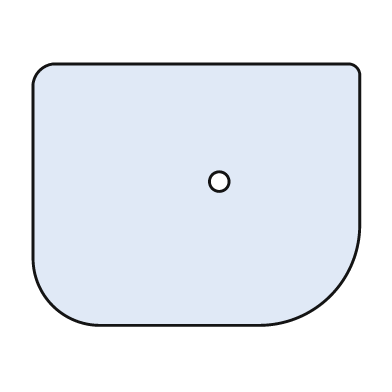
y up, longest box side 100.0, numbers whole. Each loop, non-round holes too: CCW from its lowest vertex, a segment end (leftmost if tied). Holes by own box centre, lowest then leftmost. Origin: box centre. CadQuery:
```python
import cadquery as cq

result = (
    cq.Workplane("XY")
    .moveTo(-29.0, -40.0)
    .lineTo(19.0, -40.0)
    .threePointArc((41.0, -31.0), (50.0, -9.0))
    .lineTo(50.0, 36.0)
    .threePointArc((49.0, 39.0), (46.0, 40.0))
    .lineTo(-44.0, 40.0)
    .threePointArc((-48.0, 38.0), (-50.0, 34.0))
    .lineTo(-50.0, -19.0)
    .threePointArc((-44.0, -34.0), (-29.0, -40.0))
    .close()
    .moveTo(7.0, 4.0)
    .circle(3.0)
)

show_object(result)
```